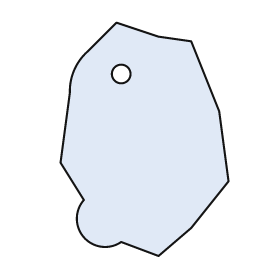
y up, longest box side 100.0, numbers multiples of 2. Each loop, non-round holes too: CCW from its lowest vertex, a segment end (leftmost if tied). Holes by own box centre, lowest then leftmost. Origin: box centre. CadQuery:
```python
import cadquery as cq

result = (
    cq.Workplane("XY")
    .moveTo(6.0, -50.0)
    .lineTo(20.0, -38.0)
    .lineTo(36.0, -18.0)
    .lineTo(32.0, 12.0)
    .lineTo(20.0, 42.0)
    .lineTo(6.0, 44.0)
    .lineTo(-12.0, 50.0)
    .lineTo(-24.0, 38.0)
    .threePointArc((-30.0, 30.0), (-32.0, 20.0))
    .lineTo(-36.0, -10.0)
    .lineTo(-26.0, -26.0)
    .threePointArc((-26.0, -42.0), (-10.0, -44.0))
    .close()
    .moveTo(-10.0, 28.0)
    .circle(4.0)
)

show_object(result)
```